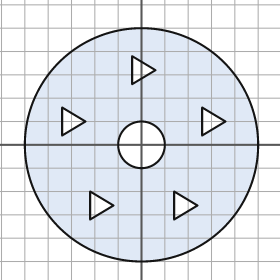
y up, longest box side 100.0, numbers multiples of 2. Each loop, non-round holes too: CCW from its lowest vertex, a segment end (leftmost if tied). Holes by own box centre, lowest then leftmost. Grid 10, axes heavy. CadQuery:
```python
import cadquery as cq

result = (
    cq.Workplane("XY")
    .moveTo(0.0, 0.0)
    .circle(50.0)
    .moveTo(-22.0, -32.0)
    .lineTo(-12.0, -26.0)
    .lineTo(-22.0, -20.0)
    .close()
    .moveTo(14.0, -32.0)
    .lineTo(24.0, -26.0)
    .lineTo(14.0, -20.0)
    .close()
    .moveTo(0.0, 0.0)
    .circle(10.0)
    .moveTo(-34.0, 4.0)
    .lineTo(-24.0, 10.0)
    .lineTo(-34.0, 16.0)
    .close()
    .moveTo(26.0, 4.0)
    .lineTo(36.0, 10.0)
    .lineTo(26.0, 16.0)
    .close()
    .moveTo(-4.0, 26.0)
    .lineTo(6.0, 32.0)
    .lineTo(-4.0, 38.0)
    .close()
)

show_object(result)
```